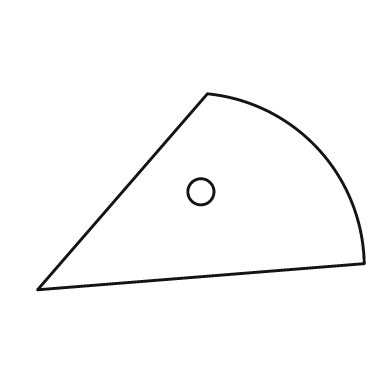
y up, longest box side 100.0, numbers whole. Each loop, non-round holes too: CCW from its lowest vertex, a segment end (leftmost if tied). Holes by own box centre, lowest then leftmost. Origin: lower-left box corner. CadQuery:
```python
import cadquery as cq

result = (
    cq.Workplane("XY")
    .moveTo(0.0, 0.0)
    .lineTo(100.0, 8.0)
    .threePointArc((86.0, 43.0), (52.0, 60.0))
    .close()
    .moveTo(50.0, 30.0)
    .circle(4.0)
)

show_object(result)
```